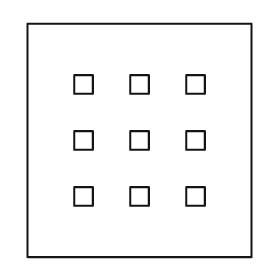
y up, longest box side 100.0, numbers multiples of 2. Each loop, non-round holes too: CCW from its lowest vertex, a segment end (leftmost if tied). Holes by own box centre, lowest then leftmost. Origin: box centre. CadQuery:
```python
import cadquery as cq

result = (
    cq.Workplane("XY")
    .moveTo(-48.0, -50.0)
    .lineTo(48.0, -50.0)
    .lineTo(48.0, 50.0)
    .lineTo(-48.0, 50.0)
    .close()
    .moveTo(-28.0, -28.0)
    .lineTo(-20.0, -28.0)
    .lineTo(-20.0, -20.0)
    .lineTo(-28.0, -20.0)
    .close()
    .moveTo(-4.0, -28.0)
    .lineTo(4.0, -28.0)
    .lineTo(4.0, -20.0)
    .lineTo(-4.0, -20.0)
    .close()
    .moveTo(20.0, -28.0)
    .lineTo(28.0, -28.0)
    .lineTo(28.0, -20.0)
    .lineTo(20.0, -20.0)
    .close()
    .moveTo(-28.0, -4.0)
    .lineTo(-20.0, -4.0)
    .lineTo(-20.0, 4.0)
    .lineTo(-28.0, 4.0)
    .close()
    .moveTo(-4.0, -4.0)
    .lineTo(4.0, -4.0)
    .lineTo(4.0, 4.0)
    .lineTo(-4.0, 4.0)
    .close()
    .moveTo(20.0, -4.0)
    .lineTo(28.0, -4.0)
    .lineTo(28.0, 4.0)
    .lineTo(20.0, 4.0)
    .close()
    .moveTo(-28.0, 20.0)
    .lineTo(-20.0, 20.0)
    .lineTo(-20.0, 28.0)
    .lineTo(-28.0, 28.0)
    .close()
    .moveTo(-4.0, 20.0)
    .lineTo(4.0, 20.0)
    .lineTo(4.0, 28.0)
    .lineTo(-4.0, 28.0)
    .close()
    .moveTo(20.0, 20.0)
    .lineTo(28.0, 20.0)
    .lineTo(28.0, 28.0)
    .lineTo(20.0, 28.0)
    .close()
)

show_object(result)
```